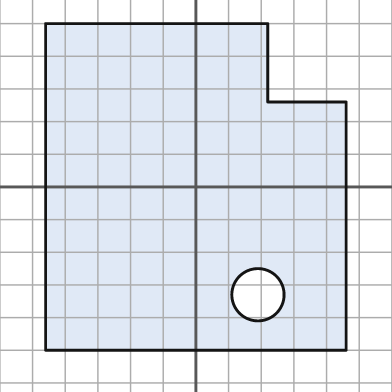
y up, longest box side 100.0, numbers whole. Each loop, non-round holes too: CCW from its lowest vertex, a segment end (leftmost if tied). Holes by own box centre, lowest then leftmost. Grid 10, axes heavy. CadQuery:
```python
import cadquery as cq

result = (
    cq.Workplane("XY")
    .moveTo(-46.0, -50.0)
    .lineTo(46.0, -50.0)
    .lineTo(46.0, 26.0)
    .lineTo(22.0, 26.0)
    .lineTo(22.0, 50.0)
    .lineTo(-46.0, 50.0)
    .close()
    .moveTo(19.0, -33.0)
    .circle(8.0)
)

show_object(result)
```